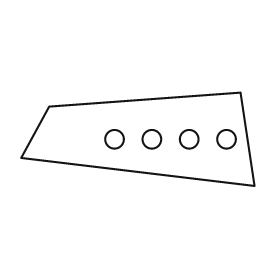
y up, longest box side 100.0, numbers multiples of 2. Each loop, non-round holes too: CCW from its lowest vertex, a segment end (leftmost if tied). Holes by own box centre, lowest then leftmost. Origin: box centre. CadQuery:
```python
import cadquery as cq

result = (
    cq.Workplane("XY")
    .moveTo(50.0, -20.0)
    .lineTo(44.0, 20.0)
    .lineTo(-38.0, 14.0)
    .lineTo(-50.0, -8.0)
    .close()
    .moveTo(-10.0, 0.0)
    .circle(4.0)
    .moveTo(6.0, 0.0)
    .circle(4.0)
    .moveTo(22.0, 0.0)
    .circle(4.0)
    .moveTo(38.0, 0.0)
    .circle(4.0)
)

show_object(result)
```